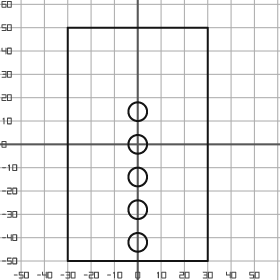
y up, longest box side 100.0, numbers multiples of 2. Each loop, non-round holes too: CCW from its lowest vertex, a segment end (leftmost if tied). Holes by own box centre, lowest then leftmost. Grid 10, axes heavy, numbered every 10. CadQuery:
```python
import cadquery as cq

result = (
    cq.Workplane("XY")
    .moveTo(-30.0, -50.0)
    .lineTo(30.0, -50.0)
    .lineTo(30.0, 50.0)
    .lineTo(-30.0, 50.0)
    .close()
    .moveTo(0.0, -42.0)
    .circle(4.0)
    .moveTo(0.0, -28.0)
    .circle(4.0)
    .moveTo(0.0, -14.0)
    .circle(4.0)
    .moveTo(0.0, 0.0)
    .circle(4.0)
    .moveTo(0.0, 14.0)
    .circle(4.0)
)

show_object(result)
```